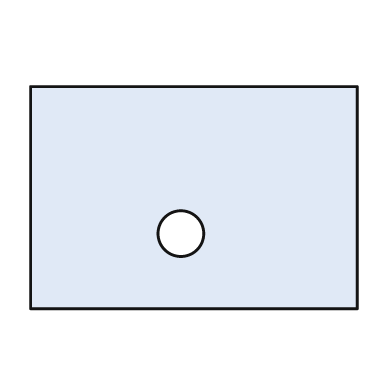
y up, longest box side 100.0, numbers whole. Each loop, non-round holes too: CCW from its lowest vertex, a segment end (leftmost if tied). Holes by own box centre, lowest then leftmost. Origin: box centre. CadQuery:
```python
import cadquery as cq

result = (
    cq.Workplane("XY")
    .moveTo(-50.0, -34.0)
    .lineTo(50.0, -34.0)
    .lineTo(50.0, 34.0)
    .lineTo(-50.0, 34.0)
    .close()
    .moveTo(-4.0, -11.0)
    .circle(7.0)
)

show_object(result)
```